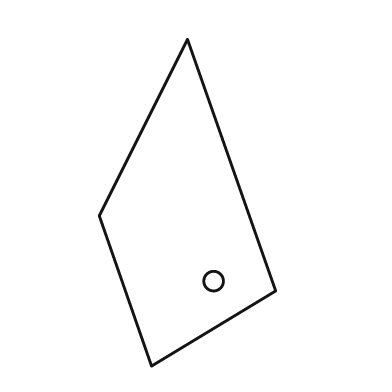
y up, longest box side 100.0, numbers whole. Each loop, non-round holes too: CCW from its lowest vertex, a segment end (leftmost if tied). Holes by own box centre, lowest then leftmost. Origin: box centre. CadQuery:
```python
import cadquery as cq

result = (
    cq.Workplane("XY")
    .moveTo(-11.0, -50.0)
    .lineTo(27.0, -27.0)
    .lineTo(0.0, 50.0)
    .lineTo(-27.0, -4.0)
    .close()
    .moveTo(8.0, -24.0)
    .circle(3.0)
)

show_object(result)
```